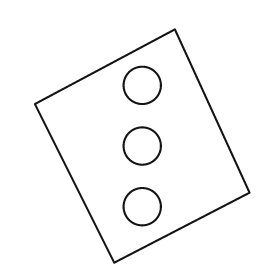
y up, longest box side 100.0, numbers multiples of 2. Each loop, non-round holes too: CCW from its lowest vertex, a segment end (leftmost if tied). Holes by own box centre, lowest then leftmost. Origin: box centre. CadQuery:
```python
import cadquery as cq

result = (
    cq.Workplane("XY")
    .moveTo(-12.0, -50.0)
    .lineTo(46.0, -20.0)
    .lineTo(14.0, 50.0)
    .lineTo(-46.0, 18.0)
    .close()
    .moveTo(0.0, -26.0)
    .circle(8.0)
    .moveTo(0.0, 0.0)
    .circle(8.0)
    .moveTo(0.0, 26.0)
    .circle(8.0)
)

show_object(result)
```